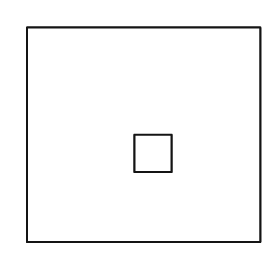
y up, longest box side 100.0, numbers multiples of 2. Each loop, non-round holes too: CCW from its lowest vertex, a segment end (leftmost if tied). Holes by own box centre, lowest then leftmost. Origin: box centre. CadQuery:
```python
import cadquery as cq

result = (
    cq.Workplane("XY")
    .moveTo(-50.0, -46.0)
    .lineTo(50.0, -46.0)
    .lineTo(50.0, 46.0)
    .lineTo(-50.0, 46.0)
    .close()
    .moveTo(-4.0, -16.0)
    .lineTo(12.0, -16.0)
    .lineTo(12.0, 0.0)
    .lineTo(-4.0, 0.0)
    .close()
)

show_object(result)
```